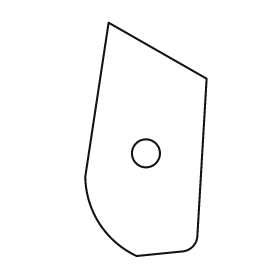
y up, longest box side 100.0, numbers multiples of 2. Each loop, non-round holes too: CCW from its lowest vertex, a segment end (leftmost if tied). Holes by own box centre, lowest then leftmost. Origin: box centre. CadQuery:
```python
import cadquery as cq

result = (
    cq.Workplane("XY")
    .moveTo(-4.0, -50.0)
    .lineTo(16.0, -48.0)
    .threePointArc((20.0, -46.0), (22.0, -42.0))
    .lineTo(26.0, 26.0)
    .lineTo(-16.0, 50.0)
    .lineTo(-26.0, -16.0)
    .threePointArc((-20.0, -36.0), (-4.0, -50.0))
    .close()
    .moveTo(0.0, -6.0)
    .circle(6.0)
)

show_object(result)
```